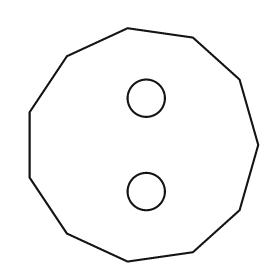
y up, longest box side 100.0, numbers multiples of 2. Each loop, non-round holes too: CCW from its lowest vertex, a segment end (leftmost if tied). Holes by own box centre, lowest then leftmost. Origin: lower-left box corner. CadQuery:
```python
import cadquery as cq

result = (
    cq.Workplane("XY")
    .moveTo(42.0, 0.0)
    .lineTo(70.0, 4.0)
    .lineTo(90.0, 22.0)
    .lineTo(98.0, 50.0)
    .lineTo(90.0, 78.0)
    .lineTo(70.0, 96.0)
    .lineTo(42.0, 100.0)
    .lineTo(16.0, 88.0)
    .lineTo(0.0, 64.0)
    .lineTo(0.0, 36.0)
    .lineTo(16.0, 12.0)
    .close()
    .moveTo(50.0, 30.0)
    .circle(8.0)
    .moveTo(50.0, 70.0)
    .circle(8.0)
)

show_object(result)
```